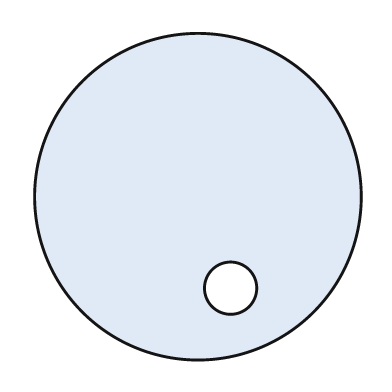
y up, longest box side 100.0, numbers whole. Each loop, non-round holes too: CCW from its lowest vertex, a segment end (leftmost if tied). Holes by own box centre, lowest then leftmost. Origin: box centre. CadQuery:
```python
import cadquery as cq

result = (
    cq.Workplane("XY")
    .moveTo(0.0, 0.0)
    .circle(50.0)
    .moveTo(10.0, -28.0)
    .circle(8.0)
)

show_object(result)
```